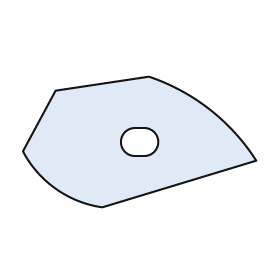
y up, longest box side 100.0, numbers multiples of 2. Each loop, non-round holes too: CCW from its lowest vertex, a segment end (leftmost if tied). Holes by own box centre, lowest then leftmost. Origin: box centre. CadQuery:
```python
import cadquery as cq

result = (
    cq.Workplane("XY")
    .moveTo(-16.0, -28.0)
    .lineTo(50.0, -8.0)
    .threePointArc((30.0, 14.0), (4.0, 28.0))
    .lineTo(-36.0, 22.0)
    .lineTo(-50.0, -4.0)
    .threePointArc((-36.0, -20.0), (-16.0, -28.0))
    .close()
    .moveTo(-2.0, -6.0)
    .lineTo(2.0, -6.0)
    .threePointArc((8.0, 0.0), (2.0, 6.0))
    .lineTo(-2.0, 6.0)
    .threePointArc((-8.0, 0.0), (-2.0, -6.0))
    .close()
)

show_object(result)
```